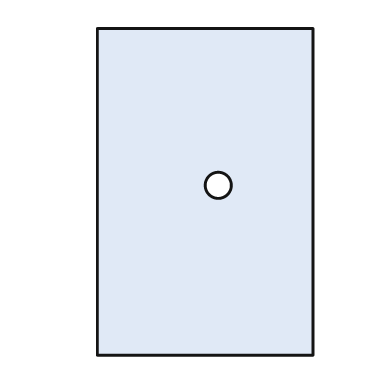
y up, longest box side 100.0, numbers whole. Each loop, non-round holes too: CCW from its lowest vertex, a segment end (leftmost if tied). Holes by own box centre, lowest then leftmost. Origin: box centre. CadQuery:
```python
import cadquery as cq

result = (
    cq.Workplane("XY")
    .moveTo(-33.0, -50.0)
    .lineTo(33.0, -50.0)
    .lineTo(33.0, 50.0)
    .lineTo(-33.0, 50.0)
    .close()
    .moveTo(4.0, 2.0)
    .circle(4.0)
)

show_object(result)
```